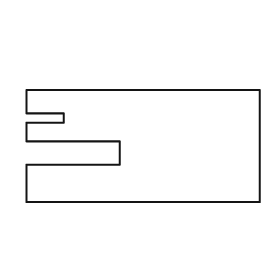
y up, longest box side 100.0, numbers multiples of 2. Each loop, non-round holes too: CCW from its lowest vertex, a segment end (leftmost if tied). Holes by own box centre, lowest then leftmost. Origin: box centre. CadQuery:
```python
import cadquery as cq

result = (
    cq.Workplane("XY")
    .moveTo(-50.0, -24.0)
    .lineTo(50.0, -24.0)
    .lineTo(50.0, 24.0)
    .lineTo(-50.0, 24.0)
    .lineTo(-50.0, 14.0)
    .lineTo(-34.0, 14.0)
    .lineTo(-34.0, 10.0)
    .lineTo(-50.0, 10.0)
    .lineTo(-50.0, 2.0)
    .lineTo(-10.0, 2.0)
    .lineTo(-10.0, -8.0)
    .lineTo(-50.0, -8.0)
    .close()
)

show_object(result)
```